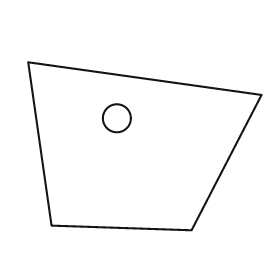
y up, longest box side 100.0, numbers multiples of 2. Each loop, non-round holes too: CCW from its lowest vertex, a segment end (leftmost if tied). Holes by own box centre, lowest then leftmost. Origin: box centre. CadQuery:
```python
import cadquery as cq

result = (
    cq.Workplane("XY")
    .moveTo(20.0, -36.0)
    .lineTo(50.0, 22.0)
    .lineTo(-50.0, 36.0)
    .lineTo(-40.0, -34.0)
    .close()
    .moveTo(-12.0, 12.0)
    .circle(6.0)
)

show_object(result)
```